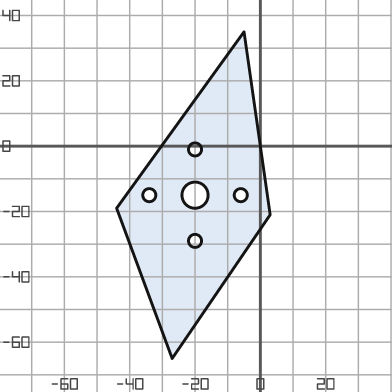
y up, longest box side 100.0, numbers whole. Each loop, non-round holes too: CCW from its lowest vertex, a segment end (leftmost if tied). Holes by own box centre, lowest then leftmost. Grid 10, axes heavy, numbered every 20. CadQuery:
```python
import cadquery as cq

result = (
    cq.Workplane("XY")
    .moveTo(-27.0, -65.0)
    .lineTo(3.0, -21.0)
    .lineTo(-5.0, 35.0)
    .lineTo(-44.0, -19.0)
    .close()
    .moveTo(-20.0, -29.0)
    .circle(2.0)
    .moveTo(-34.0, -15.0)
    .circle(2.0)
    .moveTo(-20.0, -15.0)
    .circle(4.0)
    .moveTo(-6.0, -15.0)
    .circle(2.0)
    .moveTo(-20.0, -1.0)
    .circle(2.0)
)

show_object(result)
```